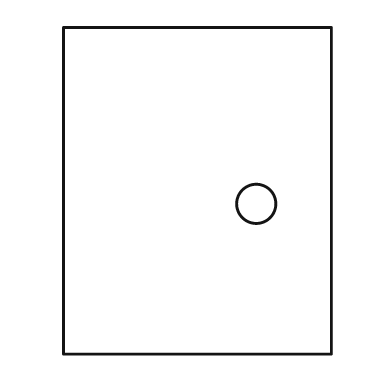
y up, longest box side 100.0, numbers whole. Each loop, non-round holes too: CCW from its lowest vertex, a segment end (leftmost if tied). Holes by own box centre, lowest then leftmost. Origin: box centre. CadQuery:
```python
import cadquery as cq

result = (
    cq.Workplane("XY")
    .moveTo(-41.0, -50.0)
    .lineTo(41.0, -50.0)
    .lineTo(41.0, 50.0)
    .lineTo(-41.0, 50.0)
    .close()
    .moveTo(18.0, -4.0)
    .circle(6.0)
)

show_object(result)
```